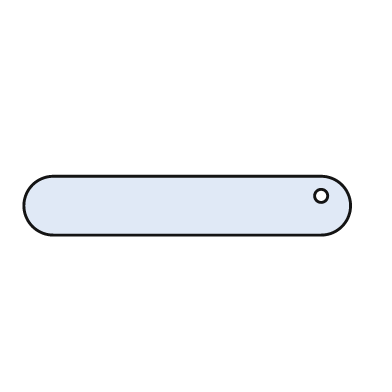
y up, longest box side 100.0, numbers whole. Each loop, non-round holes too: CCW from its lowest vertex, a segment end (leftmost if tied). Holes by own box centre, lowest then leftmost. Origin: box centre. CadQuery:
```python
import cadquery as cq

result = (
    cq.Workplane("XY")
    .moveTo(-41.0, -9.0)
    .lineTo(41.0, -9.0)
    .threePointArc((50.0, 0.0), (41.0, 9.0))
    .lineTo(-41.0, 9.0)
    .threePointArc((-50.0, 0.0), (-41.0, -9.0))
    .close()
    .moveTo(41.0, 3.0)
    .circle(2.0)
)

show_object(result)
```